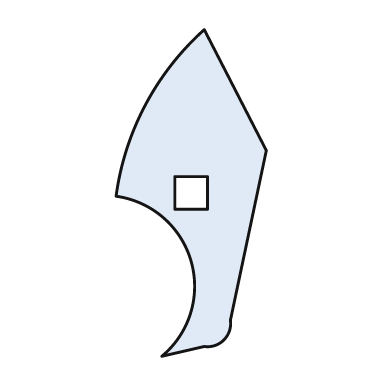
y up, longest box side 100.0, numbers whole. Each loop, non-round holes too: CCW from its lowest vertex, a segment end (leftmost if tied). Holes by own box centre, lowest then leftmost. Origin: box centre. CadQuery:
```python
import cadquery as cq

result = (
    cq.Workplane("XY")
    .moveTo(-9.0, -50.0)
    .lineTo(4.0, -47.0)
    .threePointArc((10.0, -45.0), (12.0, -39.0))
    .lineTo(23.0, 13.0)
    .lineTo(4.0, 50.0)
    .threePointArc((-14.0, 27.0), (-23.0, -1.0))
    .threePointArc((0.0, -21.0), (-9.0, -50.0))
    .close()
    .moveTo(-5.0, -5.0)
    .lineTo(5.0, -5.0)
    .lineTo(5.0, 5.0)
    .lineTo(-5.0, 5.0)
    .close()
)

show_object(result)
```